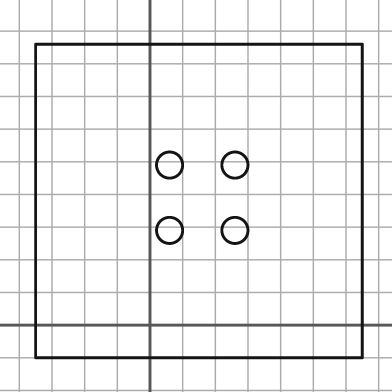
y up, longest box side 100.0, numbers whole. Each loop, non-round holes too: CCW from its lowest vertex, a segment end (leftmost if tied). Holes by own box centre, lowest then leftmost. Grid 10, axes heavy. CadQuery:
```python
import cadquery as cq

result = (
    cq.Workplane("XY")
    .moveTo(-35.0, -10.0)
    .lineTo(65.0, -10.0)
    .lineTo(65.0, 86.0)
    .lineTo(-35.0, 86.0)
    .close()
    .moveTo(6.0, 29.0)
    .circle(4.0)
    .moveTo(26.0, 29.0)
    .circle(4.0)
    .moveTo(6.0, 49.0)
    .circle(4.0)
    .moveTo(26.0, 49.0)
    .circle(4.0)
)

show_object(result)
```